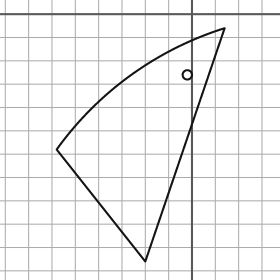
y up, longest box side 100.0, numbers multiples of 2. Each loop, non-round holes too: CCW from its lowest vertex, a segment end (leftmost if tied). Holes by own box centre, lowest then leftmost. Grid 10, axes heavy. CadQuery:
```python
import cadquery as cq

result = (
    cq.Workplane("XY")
    .moveTo(-20.0, -106.0)
    .lineTo(14.0, -6.0)
    .threePointArc((-26.0, -26.0), (-58.0, -58.0))
    .close()
    .moveTo(-2.0, -26.0)
    .circle(2.0)
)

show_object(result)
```